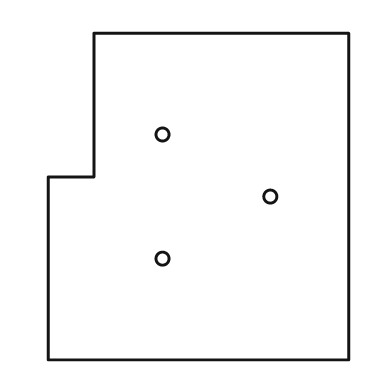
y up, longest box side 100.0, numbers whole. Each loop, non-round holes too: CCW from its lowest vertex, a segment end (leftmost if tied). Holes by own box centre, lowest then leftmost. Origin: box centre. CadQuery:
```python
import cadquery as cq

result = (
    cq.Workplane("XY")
    .moveTo(-46.0, -50.0)
    .lineTo(46.0, -50.0)
    .lineTo(46.0, 50.0)
    .lineTo(-32.0, 50.0)
    .lineTo(-32.0, 6.0)
    .lineTo(-46.0, 6.0)
    .close()
    .moveTo(-11.0, -19.0)
    .circle(2.0)
    .moveTo(22.0, 0.0)
    .circle(2.0)
    .moveTo(-11.0, 19.0)
    .circle(2.0)
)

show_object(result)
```